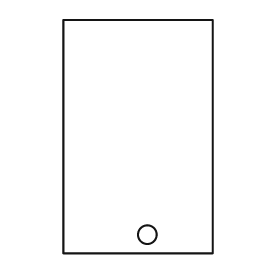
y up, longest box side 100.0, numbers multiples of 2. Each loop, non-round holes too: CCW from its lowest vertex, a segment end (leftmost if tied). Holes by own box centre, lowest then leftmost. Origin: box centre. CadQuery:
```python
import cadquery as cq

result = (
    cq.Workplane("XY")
    .moveTo(-32.0, -50.0)
    .lineTo(32.0, -50.0)
    .lineTo(32.0, 50.0)
    .lineTo(-32.0, 50.0)
    .close()
    .moveTo(4.0, -42.0)
    .circle(4.0)
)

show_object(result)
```